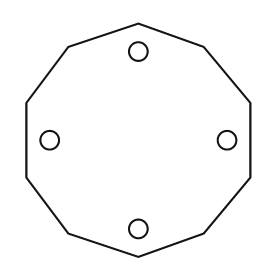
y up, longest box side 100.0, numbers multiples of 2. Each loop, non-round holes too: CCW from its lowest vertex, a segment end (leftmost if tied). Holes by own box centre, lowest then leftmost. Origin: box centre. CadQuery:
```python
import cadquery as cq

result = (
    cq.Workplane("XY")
    .moveTo(0.0, -50.0)
    .lineTo(28.0, -40.0)
    .lineTo(48.0, -16.0)
    .lineTo(48.0, 16.0)
    .lineTo(28.0, 40.0)
    .lineTo(0.0, 50.0)
    .lineTo(-30.0, 40.0)
    .lineTo(-48.0, 16.0)
    .lineTo(-48.0, -16.0)
    .lineTo(-30.0, -40.0)
    .close()
    .moveTo(0.0, -38.0)
    .circle(4.0)
    .moveTo(-38.0, 0.0)
    .circle(4.0)
    .moveTo(38.0, 0.0)
    .circle(4.0)
    .moveTo(0.0, 38.0)
    .circle(4.0)
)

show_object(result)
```